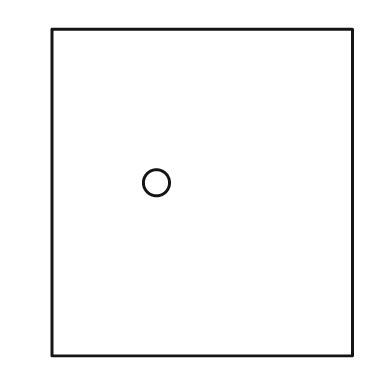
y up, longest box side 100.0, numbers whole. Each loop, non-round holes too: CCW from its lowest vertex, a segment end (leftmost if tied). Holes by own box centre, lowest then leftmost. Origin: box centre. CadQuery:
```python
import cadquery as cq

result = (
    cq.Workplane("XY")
    .moveTo(-46.0, -50.0)
    .lineTo(46.0, -50.0)
    .lineTo(46.0, 50.0)
    .lineTo(-46.0, 50.0)
    .close()
    .moveTo(-14.0, 3.0)
    .circle(4.0)
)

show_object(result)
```